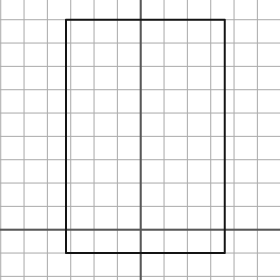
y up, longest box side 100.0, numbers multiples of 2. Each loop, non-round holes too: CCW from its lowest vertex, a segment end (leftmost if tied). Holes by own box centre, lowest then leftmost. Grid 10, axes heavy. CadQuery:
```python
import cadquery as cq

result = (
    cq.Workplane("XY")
    .moveTo(-32.0, -10.0)
    .lineTo(36.0, -10.0)
    .lineTo(36.0, 90.0)
    .lineTo(-32.0, 90.0)
    .close()
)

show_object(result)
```